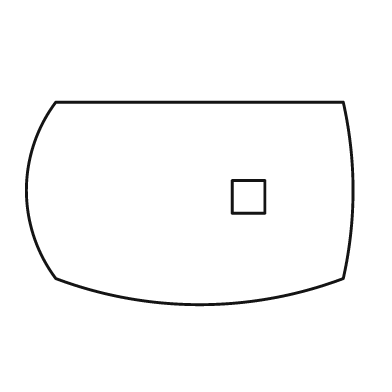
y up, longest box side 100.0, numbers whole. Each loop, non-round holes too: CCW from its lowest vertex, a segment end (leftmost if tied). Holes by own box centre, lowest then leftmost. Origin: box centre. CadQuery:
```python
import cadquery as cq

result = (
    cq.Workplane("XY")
    .moveTo(-41.0, -23.0)
    .threePointArc((3.0, -31.0), (47.0, -23.0))
    .threePointArc((50.0, 4.0), (47.0, 31.0))
    .lineTo(-41.0, 31.0)
    .threePointArc((-50.0, 4.0), (-41.0, -23.0))
    .close()
    .moveTo(13.0, -3.0)
    .lineTo(23.0, -3.0)
    .lineTo(23.0, 7.0)
    .lineTo(13.0, 7.0)
    .close()
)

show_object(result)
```